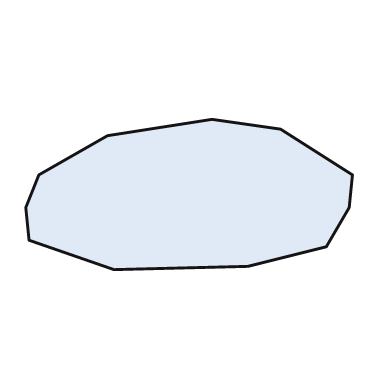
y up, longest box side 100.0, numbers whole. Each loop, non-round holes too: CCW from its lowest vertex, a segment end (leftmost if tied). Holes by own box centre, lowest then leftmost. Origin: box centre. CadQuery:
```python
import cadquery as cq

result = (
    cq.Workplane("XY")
    .moveTo(-23.0, -23.0)
    .lineTo(18.0, -22.0)
    .lineTo(42.0, -16.0)
    .lineTo(49.0, -4.0)
    .lineTo(50.0, 6.0)
    .lineTo(28.0, 20.0)
    .lineTo(7.0, 23.0)
    .lineTo(-25.0, 18.0)
    .lineTo(-46.0, 6.0)
    .lineTo(-50.0, -4.0)
    .lineTo(-49.0, -14.0)
    .close()
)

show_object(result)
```